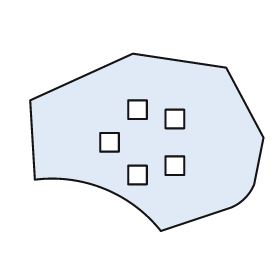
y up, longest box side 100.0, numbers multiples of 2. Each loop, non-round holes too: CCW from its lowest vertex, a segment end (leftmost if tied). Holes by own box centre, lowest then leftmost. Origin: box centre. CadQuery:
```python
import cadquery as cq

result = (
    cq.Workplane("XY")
    .moveTo(6.0, -38.0)
    .lineTo(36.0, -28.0)
    .threePointArc((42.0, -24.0), (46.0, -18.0))
    .lineTo(50.0, 2.0)
    .lineTo(34.0, 32.0)
    .lineTo(-6.0, 38.0)
    .lineTo(-50.0, 18.0)
    .lineTo(-48.0, -16.0)
    .threePointArc((-18.0, -20.0), (6.0, -38.0))
    .close()
    .moveTo(-8.0, -18.0)
    .lineTo(0.0, -18.0)
    .lineTo(0.0, -10.0)
    .lineTo(-8.0, -10.0)
    .close()
    .moveTo(8.0, -14.0)
    .lineTo(16.0, -14.0)
    .lineTo(16.0, -6.0)
    .lineTo(8.0, -6.0)
    .close()
    .moveTo(-20.0, -4.0)
    .lineTo(-12.0, -4.0)
    .lineTo(-12.0, 4.0)
    .lineTo(-20.0, 4.0)
    .close()
    .moveTo(8.0, 6.0)
    .lineTo(16.0, 6.0)
    .lineTo(16.0, 14.0)
    .lineTo(8.0, 14.0)
    .close()
    .moveTo(-8.0, 10.0)
    .lineTo(0.0, 10.0)
    .lineTo(0.0, 18.0)
    .lineTo(-8.0, 18.0)
    .close()
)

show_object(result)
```